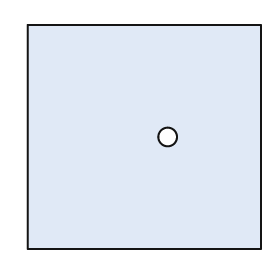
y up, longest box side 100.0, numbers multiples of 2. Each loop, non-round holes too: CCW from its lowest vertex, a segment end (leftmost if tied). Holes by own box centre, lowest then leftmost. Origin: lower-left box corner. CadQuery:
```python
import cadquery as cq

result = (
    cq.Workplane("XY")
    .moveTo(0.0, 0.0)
    .lineTo(100.0, 0.0)
    .lineTo(100.0, 96.0)
    .lineTo(0.0, 96.0)
    .close()
    .moveTo(60.0, 48.0)
    .circle(4.0)
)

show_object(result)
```